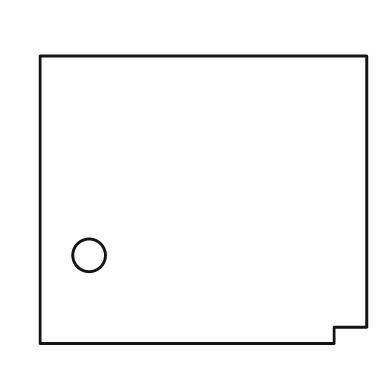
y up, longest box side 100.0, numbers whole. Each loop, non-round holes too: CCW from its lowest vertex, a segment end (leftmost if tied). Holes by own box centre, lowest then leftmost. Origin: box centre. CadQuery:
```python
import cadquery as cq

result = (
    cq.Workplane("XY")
    .moveTo(-50.0, -44.0)
    .lineTo(40.0, -44.0)
    .lineTo(40.0, -39.0)
    .lineTo(50.0, -39.0)
    .lineTo(50.0, 44.0)
    .lineTo(-50.0, 44.0)
    .close()
    .moveTo(-35.0, -17.0)
    .circle(5.0)
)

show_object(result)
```